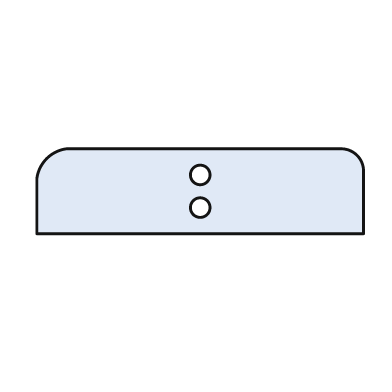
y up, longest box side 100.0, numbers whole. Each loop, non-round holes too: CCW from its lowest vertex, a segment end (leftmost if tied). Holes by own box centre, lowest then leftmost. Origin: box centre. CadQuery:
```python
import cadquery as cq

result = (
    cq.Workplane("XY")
    .moveTo(-50.0, -13.0)
    .lineTo(50.0, -13.0)
    .lineTo(50.0, 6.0)
    .threePointArc((48.0, 11.0), (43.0, 13.0))
    .lineTo(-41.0, 13.0)
    .threePointArc((-47.0, 10.0), (-50.0, 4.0))
    .close()
    .moveTo(0.0, -5.0)
    .circle(3.0)
    .moveTo(0.0, 5.0)
    .circle(3.0)
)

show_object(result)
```